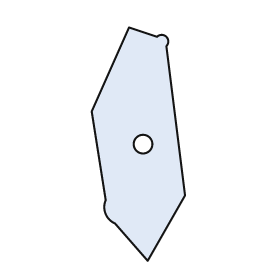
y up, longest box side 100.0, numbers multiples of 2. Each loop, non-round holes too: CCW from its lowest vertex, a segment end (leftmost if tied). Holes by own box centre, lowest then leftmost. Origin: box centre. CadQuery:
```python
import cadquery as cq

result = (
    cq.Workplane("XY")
    .moveTo(4.0, -50.0)
    .lineTo(20.0, -22.0)
    .lineTo(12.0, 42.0)
    .threePointArc((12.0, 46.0), (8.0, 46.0))
    .lineTo(-4.0, 50.0)
    .lineTo(-20.0, 14.0)
    .lineTo(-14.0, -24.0)
    .threePointArc((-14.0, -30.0), (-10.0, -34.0))
    .close()
    .moveTo(2.0, 0.0)
    .circle(4.0)
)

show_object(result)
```